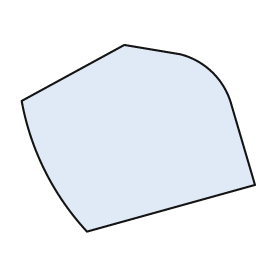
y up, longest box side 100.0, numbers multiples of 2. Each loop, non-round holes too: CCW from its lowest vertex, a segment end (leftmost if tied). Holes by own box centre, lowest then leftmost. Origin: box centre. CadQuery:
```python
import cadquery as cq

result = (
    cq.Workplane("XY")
    .moveTo(-22.0, -40.0)
    .lineTo(50.0, -20.0)
    .lineTo(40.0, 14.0)
    .threePointArc((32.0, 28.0), (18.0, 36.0))
    .lineTo(-6.0, 40.0)
    .lineTo(-50.0, 16.0)
    .threePointArc((-40.0, -14.0), (-22.0, -40.0))
    .close()
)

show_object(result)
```